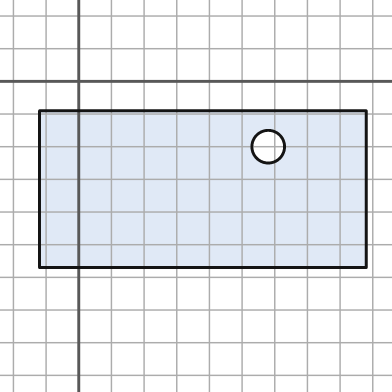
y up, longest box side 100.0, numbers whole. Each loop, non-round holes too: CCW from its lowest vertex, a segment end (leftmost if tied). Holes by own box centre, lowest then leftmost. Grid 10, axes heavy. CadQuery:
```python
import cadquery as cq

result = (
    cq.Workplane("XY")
    .moveTo(-12.0, -57.0)
    .lineTo(88.0, -57.0)
    .lineTo(88.0, -9.0)
    .lineTo(-12.0, -9.0)
    .close()
    .moveTo(58.0, -20.0)
    .circle(5.0)
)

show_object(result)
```